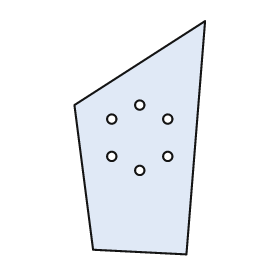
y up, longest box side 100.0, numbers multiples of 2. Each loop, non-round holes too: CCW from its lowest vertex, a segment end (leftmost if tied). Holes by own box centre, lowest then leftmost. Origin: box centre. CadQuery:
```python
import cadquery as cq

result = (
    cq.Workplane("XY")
    .moveTo(20.0, -50.0)
    .lineTo(28.0, 50.0)
    .lineTo(-28.0, 14.0)
    .lineTo(-20.0, -48.0)
    .close()
    .moveTo(0.0, -14.0)
    .circle(2.0)
    .moveTo(-12.0, -8.0)
    .circle(2.0)
    .moveTo(12.0, -8.0)
    .circle(2.0)
    .moveTo(-12.0, 8.0)
    .circle(2.0)
    .moveTo(12.0, 8.0)
    .circle(2.0)
    .moveTo(0.0, 14.0)
    .circle(2.0)
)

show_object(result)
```